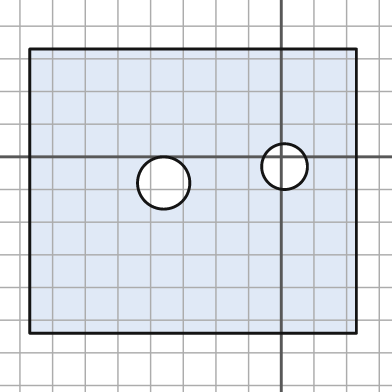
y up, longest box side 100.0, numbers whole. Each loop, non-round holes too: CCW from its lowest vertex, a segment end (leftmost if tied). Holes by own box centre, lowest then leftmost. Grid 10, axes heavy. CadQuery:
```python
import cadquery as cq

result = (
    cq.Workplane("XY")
    .moveTo(-77.0, -54.0)
    .lineTo(23.0, -54.0)
    .lineTo(23.0, 33.0)
    .lineTo(-77.0, 33.0)
    .close()
    .moveTo(-36.0, -8.0)
    .circle(8.0)
    .moveTo(1.0, -3.0)
    .circle(7.0)
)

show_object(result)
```